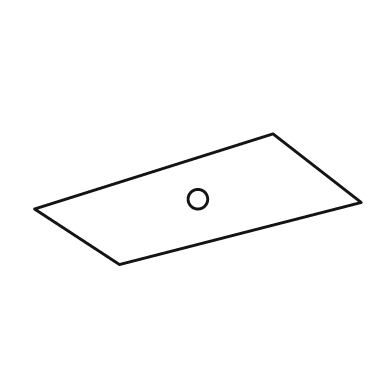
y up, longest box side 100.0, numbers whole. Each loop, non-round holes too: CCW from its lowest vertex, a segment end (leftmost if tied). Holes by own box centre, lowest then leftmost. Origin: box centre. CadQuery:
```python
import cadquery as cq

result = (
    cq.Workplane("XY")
    .moveTo(-24.0, -20.0)
    .lineTo(50.0, -1.0)
    .lineTo(23.0, 20.0)
    .lineTo(-50.0, -3.0)
    .close()
    .moveTo(0.0, 0.0)
    .circle(3.0)
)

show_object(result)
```